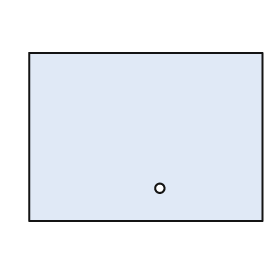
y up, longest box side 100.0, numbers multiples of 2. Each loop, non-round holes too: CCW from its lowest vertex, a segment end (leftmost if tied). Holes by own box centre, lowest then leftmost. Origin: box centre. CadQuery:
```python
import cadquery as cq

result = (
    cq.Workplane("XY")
    .moveTo(-50.0, -36.0)
    .lineTo(50.0, -36.0)
    .lineTo(50.0, 36.0)
    .lineTo(-50.0, 36.0)
    .close()
    .moveTo(6.0, -22.0)
    .circle(2.0)
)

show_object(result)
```